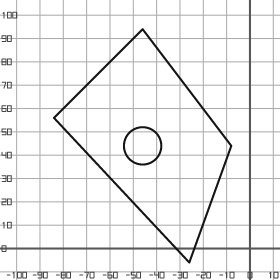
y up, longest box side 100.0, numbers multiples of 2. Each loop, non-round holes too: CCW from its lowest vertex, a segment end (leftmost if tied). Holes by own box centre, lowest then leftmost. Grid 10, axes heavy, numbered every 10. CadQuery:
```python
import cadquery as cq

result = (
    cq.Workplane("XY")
    .moveTo(-26.0, -6.0)
    .lineTo(-8.0, 44.0)
    .lineTo(-46.0, 94.0)
    .lineTo(-84.0, 56.0)
    .close()
    .moveTo(-46.0, 44.0)
    .circle(8.0)
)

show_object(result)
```